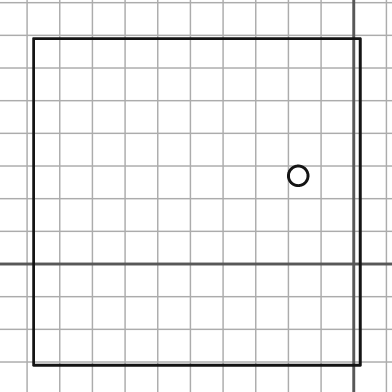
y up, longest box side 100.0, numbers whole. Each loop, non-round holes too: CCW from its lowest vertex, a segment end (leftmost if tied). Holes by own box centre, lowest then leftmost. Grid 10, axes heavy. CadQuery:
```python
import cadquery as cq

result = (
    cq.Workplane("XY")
    .moveTo(-98.0, -31.0)
    .lineTo(2.0, -31.0)
    .lineTo(2.0, 69.0)
    .lineTo(-98.0, 69.0)
    .close()
    .moveTo(-17.0, 27.0)
    .circle(3.0)
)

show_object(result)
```